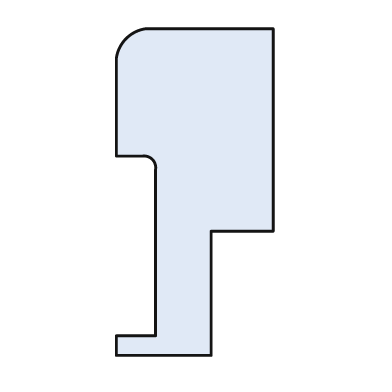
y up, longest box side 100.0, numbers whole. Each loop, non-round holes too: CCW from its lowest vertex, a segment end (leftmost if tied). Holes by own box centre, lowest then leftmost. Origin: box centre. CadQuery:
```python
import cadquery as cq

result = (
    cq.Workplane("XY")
    .moveTo(-24.0, -50.0)
    .lineTo(5.0, -50.0)
    .lineTo(5.0, -12.0)
    .lineTo(24.0, -12.0)
    .lineTo(24.0, 50.0)
    .lineTo(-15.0, 50.0)
    .threePointArc((-21.0, 47.0), (-24.0, 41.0))
    .lineTo(-24.0, 11.0)
    .lineTo(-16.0, 11.0)
    .threePointArc((-13.0, 10.0), (-12.0, 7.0))
    .lineTo(-12.0, -44.0)
    .lineTo(-24.0, -44.0)
    .close()
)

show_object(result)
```